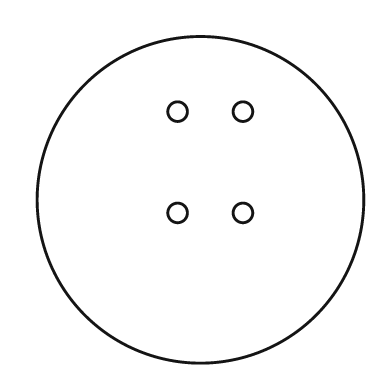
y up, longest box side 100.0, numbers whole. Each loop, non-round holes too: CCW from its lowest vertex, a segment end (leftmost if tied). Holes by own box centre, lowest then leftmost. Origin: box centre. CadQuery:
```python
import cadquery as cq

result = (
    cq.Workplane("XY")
    .moveTo(0.0, 0.0)
    .circle(50.0)
    .moveTo(-7.0, -4.0)
    .circle(3.0)
    .moveTo(13.0, -4.0)
    .circle(3.0)
    .moveTo(-7.0, 27.0)
    .circle(3.0)
    .moveTo(13.0, 27.0)
    .circle(3.0)
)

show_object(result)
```